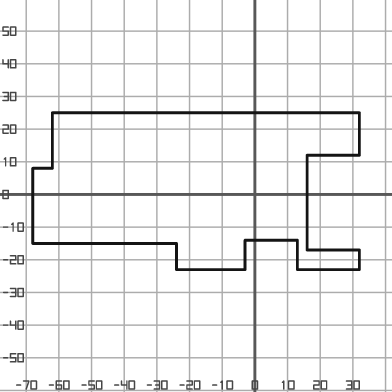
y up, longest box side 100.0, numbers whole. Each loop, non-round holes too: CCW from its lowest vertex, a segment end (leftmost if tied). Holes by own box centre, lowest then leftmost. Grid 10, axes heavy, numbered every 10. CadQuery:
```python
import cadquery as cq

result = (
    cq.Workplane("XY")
    .moveTo(-24.0, -23.0)
    .lineTo(-3.0, -23.0)
    .lineTo(-3.0, -14.0)
    .lineTo(13.0, -14.0)
    .lineTo(13.0, -23.0)
    .lineTo(32.0, -23.0)
    .lineTo(32.0, -17.0)
    .lineTo(16.0, -17.0)
    .lineTo(16.0, 12.0)
    .lineTo(32.0, 12.0)
    .lineTo(32.0, 25.0)
    .lineTo(-62.0, 25.0)
    .lineTo(-62.0, 8.0)
    .lineTo(-68.0, 8.0)
    .lineTo(-68.0, -15.0)
    .lineTo(-24.0, -15.0)
    .close()
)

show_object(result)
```